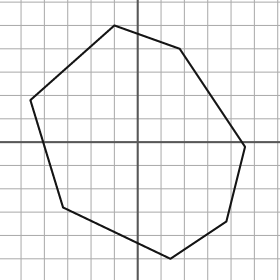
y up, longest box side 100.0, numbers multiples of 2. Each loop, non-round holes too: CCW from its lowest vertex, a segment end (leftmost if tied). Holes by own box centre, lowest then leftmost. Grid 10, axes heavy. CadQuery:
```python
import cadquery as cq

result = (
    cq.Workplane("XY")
    .moveTo(14.0, -50.0)
    .lineTo(38.0, -34.0)
    .lineTo(46.0, -2.0)
    .lineTo(18.0, 40.0)
    .lineTo(-10.0, 50.0)
    .lineTo(-46.0, 18.0)
    .lineTo(-32.0, -28.0)
    .close()
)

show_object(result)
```